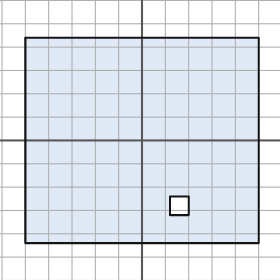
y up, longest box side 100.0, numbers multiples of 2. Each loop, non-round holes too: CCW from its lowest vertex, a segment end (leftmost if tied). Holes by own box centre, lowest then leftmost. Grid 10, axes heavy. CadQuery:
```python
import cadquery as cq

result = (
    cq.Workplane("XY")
    .moveTo(-50.0, -44.0)
    .lineTo(50.0, -44.0)
    .lineTo(50.0, 44.0)
    .lineTo(-50.0, 44.0)
    .close()
    .moveTo(12.0, -32.0)
    .lineTo(20.0, -32.0)
    .lineTo(20.0, -24.0)
    .lineTo(12.0, -24.0)
    .close()
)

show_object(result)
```